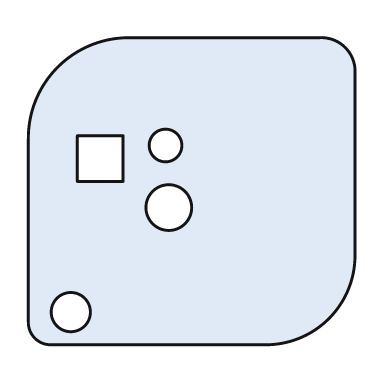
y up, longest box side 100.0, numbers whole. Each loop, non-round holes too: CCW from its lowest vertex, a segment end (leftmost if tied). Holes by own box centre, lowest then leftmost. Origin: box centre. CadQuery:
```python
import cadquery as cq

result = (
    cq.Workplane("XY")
    .moveTo(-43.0, -47.0)
    .lineTo(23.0, -47.0)
    .threePointArc((42.0, -39.0), (50.0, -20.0))
    .lineTo(50.0, 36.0)
    .threePointArc((47.0, 44.0), (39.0, 47.0))
    .lineTo(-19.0, 47.0)
    .threePointArc((-41.0, 38.0), (-50.0, 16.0))
    .lineTo(-50.0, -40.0)
    .threePointArc((-48.0, -45.0), (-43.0, -47.0))
    .close()
    .moveTo(-37.0, -37.0)
    .circle(6.0)
    .moveTo(-7.0, -5.0)
    .circle(7.0)
    .moveTo(-35.0, 3.0)
    .lineTo(-21.0, 3.0)
    .lineTo(-21.0, 17.0)
    .lineTo(-35.0, 17.0)
    .close()
    .moveTo(-8.0, 14.0)
    .circle(5.0)
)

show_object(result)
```